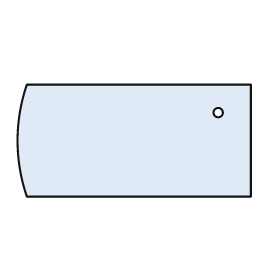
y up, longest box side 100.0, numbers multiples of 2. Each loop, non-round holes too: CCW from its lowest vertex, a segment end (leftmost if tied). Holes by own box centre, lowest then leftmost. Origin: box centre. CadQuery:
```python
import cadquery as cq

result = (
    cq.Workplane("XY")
    .moveTo(-46.0, -24.0)
    .lineTo(50.0, -24.0)
    .lineTo(50.0, 24.0)
    .lineTo(-46.0, 24.0)
    .threePointArc((-50.0, 0.0), (-46.0, -24.0))
    .close()
    .moveTo(36.0, 12.0)
    .circle(2.0)
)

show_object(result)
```